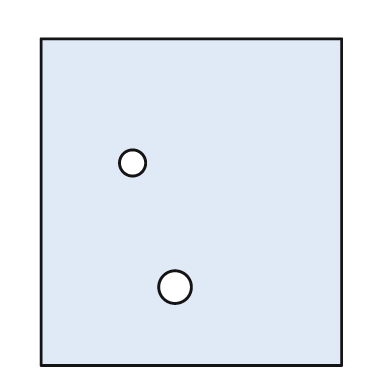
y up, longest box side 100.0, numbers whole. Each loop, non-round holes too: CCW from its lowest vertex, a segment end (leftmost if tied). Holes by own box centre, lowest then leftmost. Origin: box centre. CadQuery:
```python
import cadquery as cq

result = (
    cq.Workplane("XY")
    .moveTo(-46.0, -50.0)
    .lineTo(46.0, -50.0)
    .lineTo(46.0, 50.0)
    .lineTo(-46.0, 50.0)
    .close()
    .moveTo(-5.0, -26.0)
    .circle(5.0)
    .moveTo(-18.0, 12.0)
    .circle(4.0)
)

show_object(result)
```